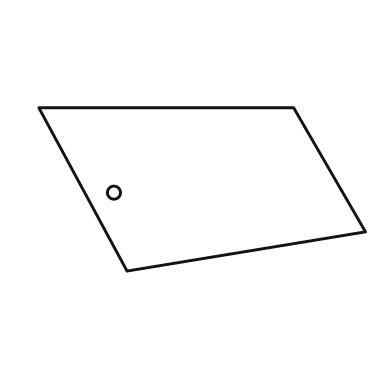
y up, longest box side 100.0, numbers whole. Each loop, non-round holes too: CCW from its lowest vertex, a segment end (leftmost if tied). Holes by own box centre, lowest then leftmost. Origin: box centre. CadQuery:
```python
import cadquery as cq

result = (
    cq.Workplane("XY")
    .moveTo(-23.0, -25.0)
    .lineTo(50.0, -13.0)
    .lineTo(28.0, 25.0)
    .lineTo(-50.0, 25.0)
    .close()
    .moveTo(-27.0, -1.0)
    .circle(2.0)
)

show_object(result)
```